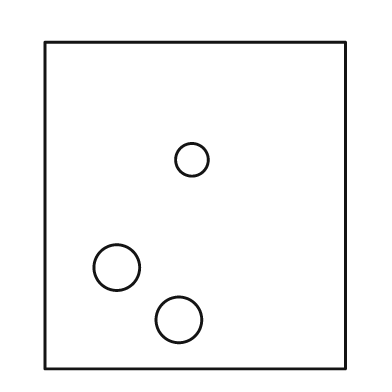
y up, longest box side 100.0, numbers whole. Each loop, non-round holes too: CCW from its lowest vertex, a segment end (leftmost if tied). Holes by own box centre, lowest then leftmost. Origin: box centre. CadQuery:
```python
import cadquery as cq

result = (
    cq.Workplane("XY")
    .moveTo(-46.0, -50.0)
    .lineTo(46.0, -50.0)
    .lineTo(46.0, 50.0)
    .lineTo(-46.0, 50.0)
    .close()
    .moveTo(-5.0, -35.0)
    .circle(7.0)
    .moveTo(-24.0, -19.0)
    .circle(7.0)
    .moveTo(-1.0, 14.0)
    .circle(5.0)
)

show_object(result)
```